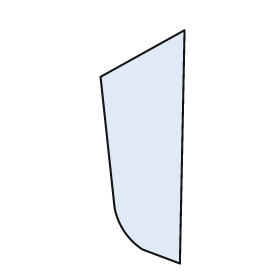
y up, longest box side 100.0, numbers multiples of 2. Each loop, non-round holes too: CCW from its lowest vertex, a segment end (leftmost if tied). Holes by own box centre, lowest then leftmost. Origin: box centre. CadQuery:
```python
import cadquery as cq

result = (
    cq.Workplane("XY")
    .moveTo(16.0, -50.0)
    .lineTo(18.0, 50.0)
    .lineTo(-18.0, 30.0)
    .lineTo(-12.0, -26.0)
    .threePointArc((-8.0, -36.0), (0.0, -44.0))
    .close()
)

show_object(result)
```